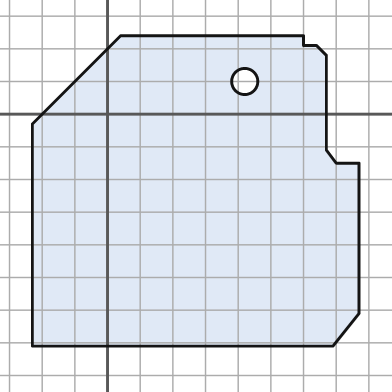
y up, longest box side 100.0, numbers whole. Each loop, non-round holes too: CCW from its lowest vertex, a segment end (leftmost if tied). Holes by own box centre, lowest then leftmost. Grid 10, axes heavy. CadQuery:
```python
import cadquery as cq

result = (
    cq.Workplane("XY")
    .moveTo(-23.0, -71.0)
    .lineTo(69.0, -71.0)
    .lineTo(77.0, -61.0)
    .lineTo(77.0, -15.0)
    .lineTo(70.0, -15.0)
    .lineTo(67.0, -11.0)
    .lineTo(67.0, 18.0)
    .lineTo(64.0, 21.0)
    .lineTo(60.0, 21.0)
    .lineTo(60.0, 24.0)
    .lineTo(4.0, 24.0)
    .lineTo(-23.0, -3.0)
    .close()
    .moveTo(42.0, 10.0)
    .circle(4.0)
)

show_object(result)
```